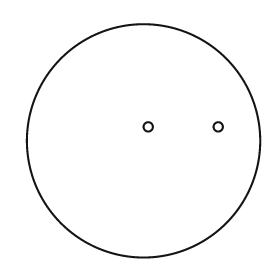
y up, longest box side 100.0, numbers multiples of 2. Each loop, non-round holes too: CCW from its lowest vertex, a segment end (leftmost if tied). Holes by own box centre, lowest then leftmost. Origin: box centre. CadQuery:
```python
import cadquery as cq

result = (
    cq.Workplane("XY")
    .moveTo(0.0, 0.0)
    .circle(50.0)
    .moveTo(2.0, 6.0)
    .circle(2.0)
    .moveTo(32.0, 6.0)
    .circle(2.0)
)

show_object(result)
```